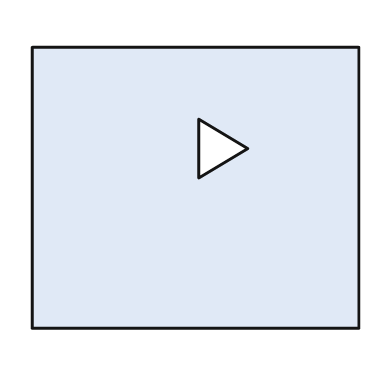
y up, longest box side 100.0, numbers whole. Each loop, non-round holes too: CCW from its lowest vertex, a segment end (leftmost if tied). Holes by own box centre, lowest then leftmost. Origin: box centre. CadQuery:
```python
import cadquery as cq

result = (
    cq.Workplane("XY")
    .moveTo(-50.0, -43.0)
    .lineTo(50.0, -43.0)
    .lineTo(50.0, 43.0)
    .lineTo(-50.0, 43.0)
    .close()
    .moveTo(1.0, 3.0)
    .lineTo(16.0, 12.0)
    .lineTo(1.0, 21.0)
    .close()
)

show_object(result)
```